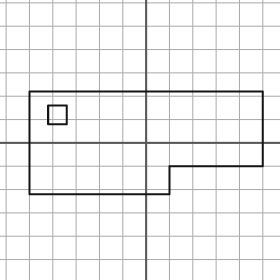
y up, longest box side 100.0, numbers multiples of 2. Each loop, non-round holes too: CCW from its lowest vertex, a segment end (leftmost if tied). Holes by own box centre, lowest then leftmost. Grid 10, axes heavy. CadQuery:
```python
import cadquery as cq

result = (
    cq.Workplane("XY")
    .moveTo(-50.0, -22.0)
    .lineTo(10.0, -22.0)
    .lineTo(10.0, -10.0)
    .lineTo(50.0, -10.0)
    .lineTo(50.0, 22.0)
    .lineTo(-50.0, 22.0)
    .close()
    .moveTo(-42.0, 8.0)
    .lineTo(-34.0, 8.0)
    .lineTo(-34.0, 16.0)
    .lineTo(-42.0, 16.0)
    .close()
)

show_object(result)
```